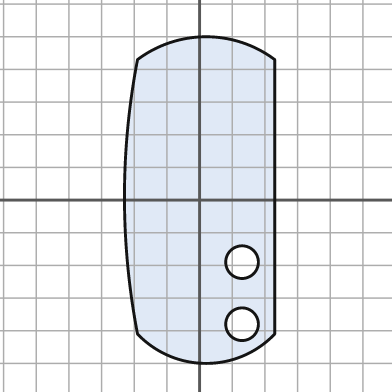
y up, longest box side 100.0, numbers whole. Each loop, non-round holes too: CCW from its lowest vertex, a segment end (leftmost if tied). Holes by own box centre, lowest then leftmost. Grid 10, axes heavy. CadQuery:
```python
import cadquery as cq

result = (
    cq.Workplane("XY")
    .moveTo(-19.0, -41.0)
    .threePointArc((2.0, -50.0), (23.0, -41.0))
    .lineTo(23.0, 43.0)
    .threePointArc((2.0, 50.0), (-19.0, 43.0))
    .threePointArc((-23.0, 1.0), (-19.0, -41.0))
    .close()
    .moveTo(13.0, -38.0)
    .circle(5.0)
    .moveTo(13.0, -19.0)
    .circle(5.0)
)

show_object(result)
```